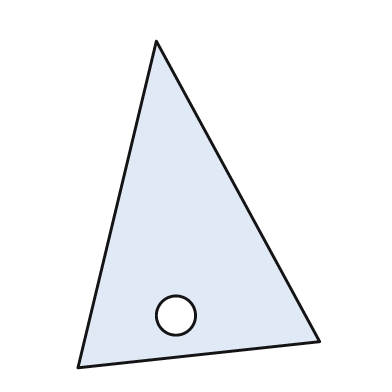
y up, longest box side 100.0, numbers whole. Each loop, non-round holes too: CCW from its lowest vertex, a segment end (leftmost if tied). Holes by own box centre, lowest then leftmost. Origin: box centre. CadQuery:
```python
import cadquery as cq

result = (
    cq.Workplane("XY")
    .moveTo(-37.0, -50.0)
    .lineTo(37.0, -42.0)
    .lineTo(-13.0, 50.0)
    .close()
    .moveTo(-7.0, -34.0)
    .circle(6.0)
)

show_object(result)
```